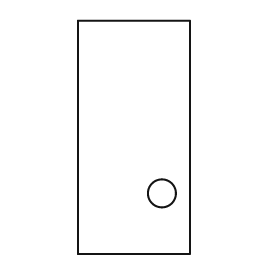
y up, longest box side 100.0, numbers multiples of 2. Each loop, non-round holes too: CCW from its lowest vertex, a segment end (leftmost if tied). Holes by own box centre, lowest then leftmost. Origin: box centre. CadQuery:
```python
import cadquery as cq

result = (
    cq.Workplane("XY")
    .moveTo(-24.0, -50.0)
    .lineTo(24.0, -50.0)
    .lineTo(24.0, 50.0)
    .lineTo(-24.0, 50.0)
    .close()
    .moveTo(12.0, -24.0)
    .circle(6.0)
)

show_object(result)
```